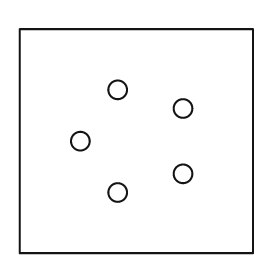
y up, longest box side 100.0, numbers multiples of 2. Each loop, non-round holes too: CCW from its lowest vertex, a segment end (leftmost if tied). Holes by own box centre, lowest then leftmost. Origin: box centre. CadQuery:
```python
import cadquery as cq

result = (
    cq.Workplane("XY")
    .moveTo(-50.0, -48.0)
    .lineTo(50.0, -48.0)
    .lineTo(50.0, 48.0)
    .lineTo(-50.0, 48.0)
    .close()
    .moveTo(-8.0, -22.0)
    .circle(4.0)
    .moveTo(20.0, -14.0)
    .circle(4.0)
    .moveTo(-24.0, 0.0)
    .circle(4.0)
    .moveTo(20.0, 14.0)
    .circle(4.0)
    .moveTo(-8.0, 22.0)
    .circle(4.0)
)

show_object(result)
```